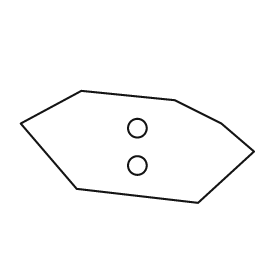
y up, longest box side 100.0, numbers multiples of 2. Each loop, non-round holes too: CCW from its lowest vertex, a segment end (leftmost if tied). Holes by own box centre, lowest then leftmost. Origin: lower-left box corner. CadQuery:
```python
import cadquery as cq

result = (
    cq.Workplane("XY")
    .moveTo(76.0, 0.0)
    .lineTo(100.0, 22.0)
    .lineTo(86.0, 34.0)
    .lineTo(66.0, 44.0)
    .lineTo(26.0, 48.0)
    .lineTo(0.0, 34.0)
    .lineTo(24.0, 6.0)
    .close()
    .moveTo(50.0, 16.0)
    .circle(4.0)
    .moveTo(50.0, 32.0)
    .circle(4.0)
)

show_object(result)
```